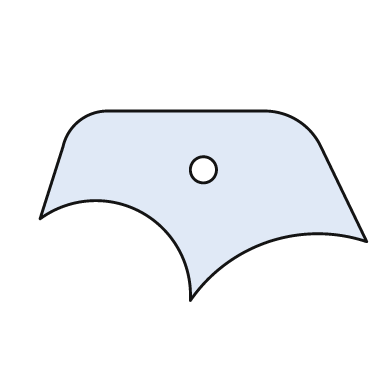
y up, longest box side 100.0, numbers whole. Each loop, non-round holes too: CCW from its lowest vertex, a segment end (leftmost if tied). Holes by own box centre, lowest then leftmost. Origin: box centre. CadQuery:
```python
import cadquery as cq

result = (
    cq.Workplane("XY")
    .moveTo(-4.0, -29.0)
    .threePointArc((20.0, -11.0), (50.0, -11.0))
    .lineTo(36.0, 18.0)
    .threePointArc((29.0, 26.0), (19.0, 29.0))
    .lineTo(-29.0, 29.0)
    .threePointArc((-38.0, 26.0), (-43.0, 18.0))
    .lineTo(-50.0, -4.0)
    .threePointArc((-19.0, -2.0), (-4.0, -29.0))
    .close()
    .moveTo(0.0, 11.0)
    .circle(4.0)
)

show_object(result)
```